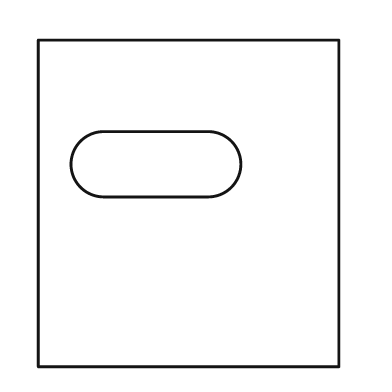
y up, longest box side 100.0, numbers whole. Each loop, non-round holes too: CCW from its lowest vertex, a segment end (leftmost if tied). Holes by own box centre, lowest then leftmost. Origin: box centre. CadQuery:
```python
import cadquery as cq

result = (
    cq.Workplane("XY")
    .moveTo(-46.0, -50.0)
    .lineTo(46.0, -50.0)
    .lineTo(46.0, 50.0)
    .lineTo(-46.0, 50.0)
    .close()
    .moveTo(-26.0, 2.0)
    .lineTo(6.0, 2.0)
    .threePointArc((16.0, 12.0), (6.0, 22.0))
    .lineTo(-26.0, 22.0)
    .threePointArc((-36.0, 12.0), (-26.0, 2.0))
    .close()
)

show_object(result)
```